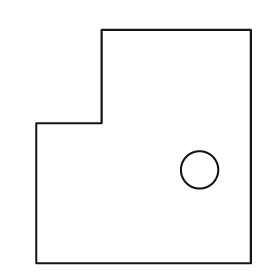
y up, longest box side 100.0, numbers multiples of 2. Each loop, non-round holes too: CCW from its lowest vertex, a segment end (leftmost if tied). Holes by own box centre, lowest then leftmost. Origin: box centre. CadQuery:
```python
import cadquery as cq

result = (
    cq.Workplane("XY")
    .moveTo(-46.0, -50.0)
    .lineTo(46.0, -50.0)
    .lineTo(46.0, 50.0)
    .lineTo(-18.0, 50.0)
    .lineTo(-18.0, 10.0)
    .lineTo(-46.0, 10.0)
    .close()
    .moveTo(24.0, -10.0)
    .circle(8.0)
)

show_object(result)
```